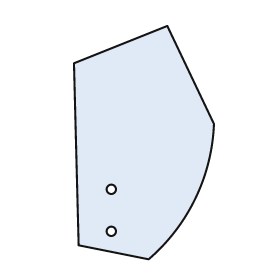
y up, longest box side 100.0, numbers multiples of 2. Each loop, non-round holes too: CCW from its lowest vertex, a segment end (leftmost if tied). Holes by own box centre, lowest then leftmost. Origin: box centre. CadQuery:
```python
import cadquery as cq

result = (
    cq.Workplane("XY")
    .moveTo(2.0, -50.0)
    .threePointArc((22.0, -24.0), (30.0, 8.0))
    .lineTo(10.0, 50.0)
    .lineTo(-30.0, 34.0)
    .lineTo(-28.0, -44.0)
    .close()
    .moveTo(-14.0, -38.0)
    .circle(2.0)
    .moveTo(-14.0, -20.0)
    .circle(2.0)
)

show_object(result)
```